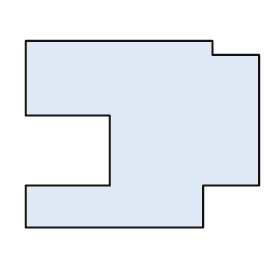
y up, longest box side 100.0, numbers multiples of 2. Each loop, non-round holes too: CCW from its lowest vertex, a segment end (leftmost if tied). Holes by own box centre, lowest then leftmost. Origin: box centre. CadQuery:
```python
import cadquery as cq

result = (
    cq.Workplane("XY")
    .moveTo(-50.0, -40.0)
    .lineTo(26.0, -40.0)
    .lineTo(26.0, -22.0)
    .lineTo(50.0, -22.0)
    .lineTo(50.0, 34.0)
    .lineTo(30.0, 34.0)
    .lineTo(30.0, 40.0)
    .lineTo(-50.0, 40.0)
    .lineTo(-50.0, 8.0)
    .lineTo(-14.0, 8.0)
    .lineTo(-14.0, -22.0)
    .lineTo(-50.0, -22.0)
    .close()
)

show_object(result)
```